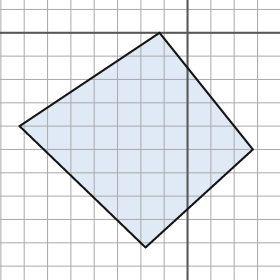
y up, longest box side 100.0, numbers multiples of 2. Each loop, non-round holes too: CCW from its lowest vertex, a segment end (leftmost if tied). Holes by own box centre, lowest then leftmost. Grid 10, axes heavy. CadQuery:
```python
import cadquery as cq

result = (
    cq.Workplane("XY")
    .moveTo(-18.0, -92.0)
    .lineTo(28.0, -50.0)
    .lineTo(-12.0, 0.0)
    .lineTo(-72.0, -40.0)
    .close()
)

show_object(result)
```